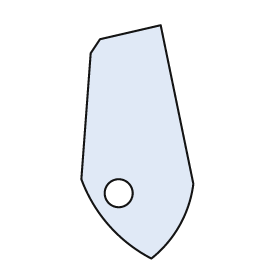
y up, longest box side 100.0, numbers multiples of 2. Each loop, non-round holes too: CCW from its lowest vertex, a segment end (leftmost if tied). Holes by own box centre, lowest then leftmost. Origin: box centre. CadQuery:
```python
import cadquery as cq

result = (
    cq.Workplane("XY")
    .moveTo(6.0, -50.0)
    .threePointArc((18.0, -36.0), (24.0, -18.0))
    .lineTo(10.0, 50.0)
    .lineTo(-16.0, 44.0)
    .lineTo(-20.0, 38.0)
    .lineTo(-24.0, -16.0)
    .threePointArc((-12.0, -36.0), (6.0, -50.0))
    .close()
    .moveTo(-8.0, -22.0)
    .circle(6.0)
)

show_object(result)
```